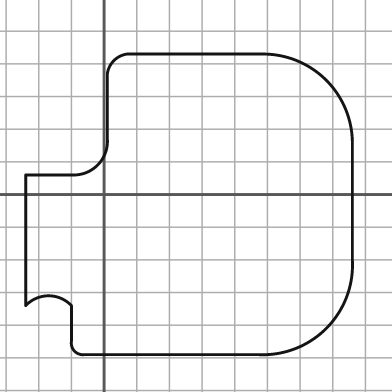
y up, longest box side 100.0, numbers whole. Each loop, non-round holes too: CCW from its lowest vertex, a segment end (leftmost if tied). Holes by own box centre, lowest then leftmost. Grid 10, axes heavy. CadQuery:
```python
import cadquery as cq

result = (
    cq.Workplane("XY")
    .moveTo(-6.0, -49.0)
    .lineTo(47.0, -49.0)
    .threePointArc((68.0, -41.0), (76.0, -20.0))
    .lineTo(76.0, 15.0)
    .threePointArc((68.0, 35.0), (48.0, 43.0))
    .lineTo(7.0, 43.0)
    .threePointArc((3.0, 41.0), (1.0, 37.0))
    .lineTo(1.0, 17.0)
    .threePointArc((-2.0, 9.0), (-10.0, 6.0))
    .lineTo(-24.0, 6.0)
    .lineTo(-24.0, -34.0)
    .threePointArc((-17.0, -31.0), (-10.0, -34.0))
    .lineTo(-10.0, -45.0)
    .threePointArc((-9.0, -48.0), (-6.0, -49.0))
    .close()
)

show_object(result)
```